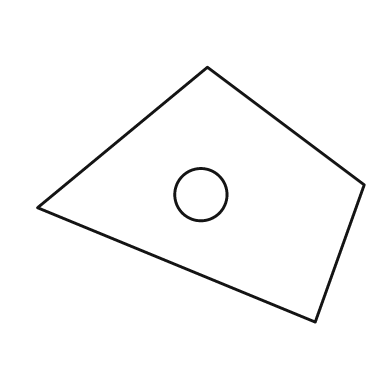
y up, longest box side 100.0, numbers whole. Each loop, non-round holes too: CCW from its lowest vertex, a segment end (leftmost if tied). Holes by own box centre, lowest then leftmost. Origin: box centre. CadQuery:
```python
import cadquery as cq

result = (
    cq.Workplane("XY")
    .moveTo(35.0, -39.0)
    .lineTo(50.0, 3.0)
    .lineTo(2.0, 39.0)
    .lineTo(-50.0, -4.0)
    .close()
    .moveTo(0.0, 0.0)
    .circle(8.0)
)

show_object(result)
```